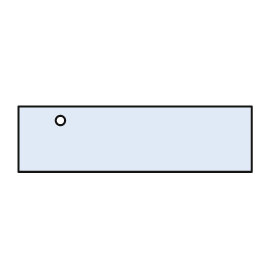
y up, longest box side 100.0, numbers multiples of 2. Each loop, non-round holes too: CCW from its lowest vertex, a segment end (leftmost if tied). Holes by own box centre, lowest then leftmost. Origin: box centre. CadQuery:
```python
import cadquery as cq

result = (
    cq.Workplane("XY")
    .moveTo(-50.0, -14.0)
    .lineTo(50.0, -14.0)
    .lineTo(50.0, 14.0)
    .lineTo(-50.0, 14.0)
    .close()
    .moveTo(-32.0, 8.0)
    .circle(2.0)
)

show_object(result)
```